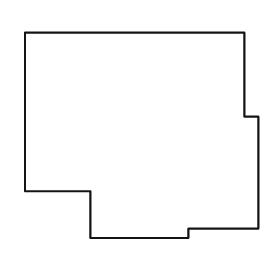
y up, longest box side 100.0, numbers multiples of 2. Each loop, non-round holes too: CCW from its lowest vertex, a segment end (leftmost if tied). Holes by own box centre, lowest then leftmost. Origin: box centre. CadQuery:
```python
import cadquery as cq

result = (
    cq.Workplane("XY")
    .moveTo(-22.0, -44.0)
    .lineTo(20.0, -44.0)
    .lineTo(20.0, -40.0)
    .lineTo(50.0, -40.0)
    .lineTo(50.0, 8.0)
    .lineTo(44.0, 8.0)
    .lineTo(44.0, 44.0)
    .lineTo(-50.0, 44.0)
    .lineTo(-50.0, -24.0)
    .lineTo(-22.0, -24.0)
    .close()
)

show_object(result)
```